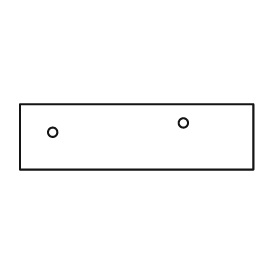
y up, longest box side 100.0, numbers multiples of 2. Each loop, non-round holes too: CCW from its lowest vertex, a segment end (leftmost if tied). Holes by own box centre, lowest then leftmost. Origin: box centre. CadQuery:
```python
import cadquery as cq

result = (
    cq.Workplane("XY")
    .moveTo(-50.0, -14.0)
    .lineTo(50.0, -14.0)
    .lineTo(50.0, 14.0)
    .lineTo(-50.0, 14.0)
    .close()
    .moveTo(-36.0, 2.0)
    .circle(2.0)
    .moveTo(20.0, 6.0)
    .circle(2.0)
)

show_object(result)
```